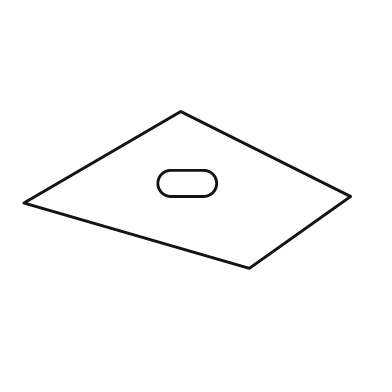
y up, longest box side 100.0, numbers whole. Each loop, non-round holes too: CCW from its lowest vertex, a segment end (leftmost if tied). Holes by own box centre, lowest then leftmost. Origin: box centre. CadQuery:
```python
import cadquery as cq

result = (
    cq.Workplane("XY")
    .moveTo(19.0, -24.0)
    .lineTo(50.0, -2.0)
    .lineTo(-2.0, 24.0)
    .lineTo(-50.0, -4.0)
    .close()
    .moveTo(-5.0, -2.0)
    .lineTo(5.0, -2.0)
    .threePointArc((9.0, 2.0), (5.0, 6.0))
    .lineTo(-5.0, 6.0)
    .threePointArc((-9.0, 2.0), (-5.0, -2.0))
    .close()
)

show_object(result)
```